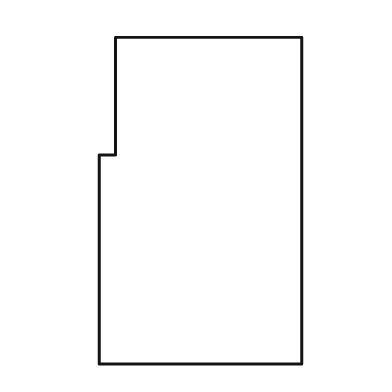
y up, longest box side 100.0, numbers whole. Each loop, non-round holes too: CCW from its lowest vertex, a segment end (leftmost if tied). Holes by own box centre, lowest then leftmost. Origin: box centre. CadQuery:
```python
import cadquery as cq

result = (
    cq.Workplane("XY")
    .moveTo(-31.0, -50.0)
    .lineTo(31.0, -50.0)
    .lineTo(31.0, 50.0)
    .lineTo(-26.0, 50.0)
    .lineTo(-26.0, 14.0)
    .lineTo(-31.0, 14.0)
    .close()
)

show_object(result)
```